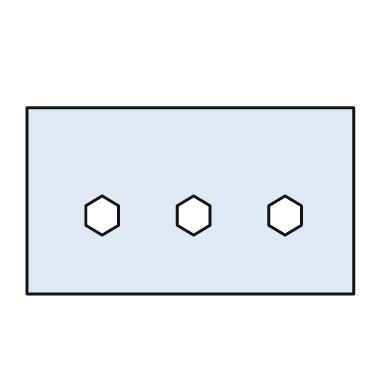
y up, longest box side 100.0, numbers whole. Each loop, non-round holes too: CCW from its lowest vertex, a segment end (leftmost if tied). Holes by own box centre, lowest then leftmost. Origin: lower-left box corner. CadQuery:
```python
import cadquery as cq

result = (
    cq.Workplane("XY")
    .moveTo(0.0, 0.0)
    .lineTo(100.0, 0.0)
    .lineTo(100.0, 57.0)
    .lineTo(0.0, 57.0)
    .close()
    .moveTo(23.0, 18.0)
    .lineTo(28.0, 21.0)
    .lineTo(28.0, 27.0)
    .lineTo(23.0, 30.0)
    .lineTo(18.0, 27.0)
    .lineTo(18.0, 21.0)
    .close()
    .moveTo(51.0, 18.0)
    .lineTo(56.0, 21.0)
    .lineTo(56.0, 27.0)
    .lineTo(51.0, 30.0)
    .lineTo(46.0, 27.0)
    .lineTo(46.0, 21.0)
    .close()
    .moveTo(79.0, 18.0)
    .lineTo(84.0, 21.0)
    .lineTo(84.0, 27.0)
    .lineTo(79.0, 30.0)
    .lineTo(74.0, 27.0)
    .lineTo(74.0, 21.0)
    .close()
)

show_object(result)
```